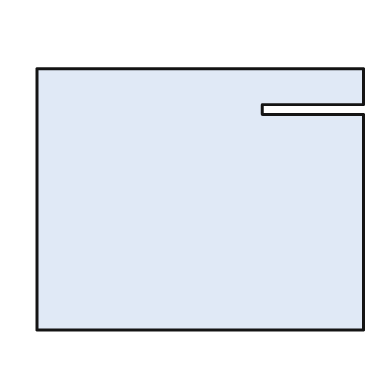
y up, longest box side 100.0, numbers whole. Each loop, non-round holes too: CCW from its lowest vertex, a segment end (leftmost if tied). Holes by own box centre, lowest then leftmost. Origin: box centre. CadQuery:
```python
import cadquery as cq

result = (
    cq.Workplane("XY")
    .moveTo(-50.0, -40.0)
    .lineTo(50.0, -40.0)
    .lineTo(50.0, 26.0)
    .lineTo(19.0, 26.0)
    .lineTo(19.0, 29.0)
    .lineTo(50.0, 29.0)
    .lineTo(50.0, 40.0)
    .lineTo(-50.0, 40.0)
    .close()
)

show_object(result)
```